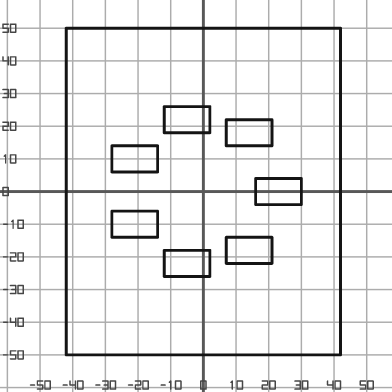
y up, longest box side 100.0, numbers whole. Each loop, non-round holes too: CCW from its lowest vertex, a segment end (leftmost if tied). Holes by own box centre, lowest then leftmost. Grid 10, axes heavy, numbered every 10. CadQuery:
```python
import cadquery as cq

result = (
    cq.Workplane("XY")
    .moveTo(-42.0, -50.0)
    .lineTo(42.0, -50.0)
    .lineTo(42.0, 50.0)
    .lineTo(-42.0, 50.0)
    .close()
    .moveTo(-12.0, -26.0)
    .lineTo(2.0, -26.0)
    .lineTo(2.0, -18.0)
    .lineTo(-12.0, -18.0)
    .close()
    .moveTo(7.0, -22.0)
    .lineTo(21.0, -22.0)
    .lineTo(21.0, -14.0)
    .lineTo(7.0, -14.0)
    .close()
    .moveTo(-28.0, -14.0)
    .lineTo(-14.0, -14.0)
    .lineTo(-14.0, -6.0)
    .lineTo(-28.0, -6.0)
    .close()
    .moveTo(16.0, -4.0)
    .lineTo(30.0, -4.0)
    .lineTo(30.0, 4.0)
    .lineTo(16.0, 4.0)
    .close()
    .moveTo(-28.0, 6.0)
    .lineTo(-14.0, 6.0)
    .lineTo(-14.0, 14.0)
    .lineTo(-28.0, 14.0)
    .close()
    .moveTo(7.0, 14.0)
    .lineTo(21.0, 14.0)
    .lineTo(21.0, 22.0)
    .lineTo(7.0, 22.0)
    .close()
    .moveTo(-12.0, 18.0)
    .lineTo(2.0, 18.0)
    .lineTo(2.0, 26.0)
    .lineTo(-12.0, 26.0)
    .close()
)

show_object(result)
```